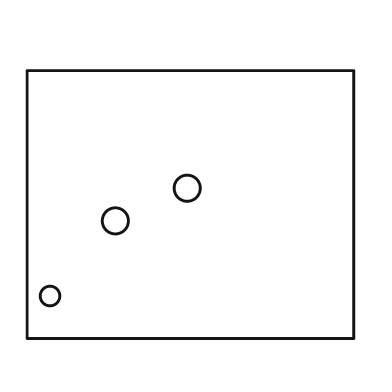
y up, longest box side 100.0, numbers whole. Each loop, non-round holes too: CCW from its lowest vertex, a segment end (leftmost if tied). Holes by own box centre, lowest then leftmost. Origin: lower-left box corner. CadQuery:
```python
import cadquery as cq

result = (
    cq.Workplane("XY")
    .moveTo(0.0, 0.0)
    .lineTo(100.0, 0.0)
    .lineTo(100.0, 82.0)
    .lineTo(0.0, 82.0)
    .close()
    .moveTo(7.0, 13.0)
    .circle(3.0)
    .moveTo(27.0, 36.0)
    .circle(4.0)
    .moveTo(49.0, 46.0)
    .circle(4.0)
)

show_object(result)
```